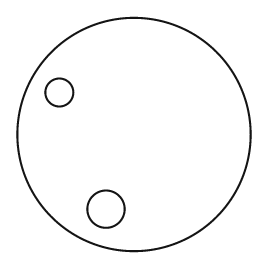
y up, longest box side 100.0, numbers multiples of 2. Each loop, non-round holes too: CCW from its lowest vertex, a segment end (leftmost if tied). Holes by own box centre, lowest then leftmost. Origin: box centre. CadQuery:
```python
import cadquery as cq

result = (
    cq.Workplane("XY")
    .moveTo(0.0, 0.0)
    .circle(50.0)
    .moveTo(-12.0, -32.0)
    .circle(8.0)
    .moveTo(-32.0, 18.0)
    .circle(6.0)
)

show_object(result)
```